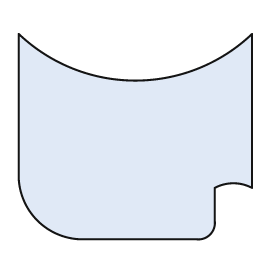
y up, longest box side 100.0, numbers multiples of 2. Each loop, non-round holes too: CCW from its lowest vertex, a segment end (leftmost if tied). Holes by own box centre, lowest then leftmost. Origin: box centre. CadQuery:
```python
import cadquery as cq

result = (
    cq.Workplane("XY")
    .moveTo(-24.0, -44.0)
    .lineTo(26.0, -44.0)
    .threePointArc((32.0, -42.0), (34.0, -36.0))
    .lineTo(34.0, -22.0)
    .threePointArc((42.0, -20.0), (50.0, -22.0))
    .lineTo(50.0, 44.0)
    .threePointArc((0.0, 24.0), (-50.0, 44.0))
    .lineTo(-50.0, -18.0)
    .threePointArc((-42.0, -36.0), (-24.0, -44.0))
    .close()
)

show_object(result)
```